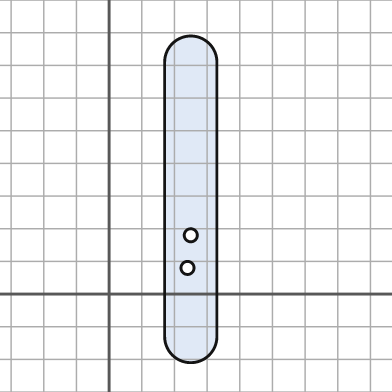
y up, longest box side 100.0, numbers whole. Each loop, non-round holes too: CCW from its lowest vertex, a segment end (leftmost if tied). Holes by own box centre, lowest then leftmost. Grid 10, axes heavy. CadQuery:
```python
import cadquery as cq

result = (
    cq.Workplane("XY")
    .moveTo(17.0, -13.0)
    .threePointArc((25.0, -21.0), (33.0, -13.0))
    .lineTo(33.0, 71.0)
    .threePointArc((25.0, 79.0), (17.0, 71.0))
    .close()
    .moveTo(24.0, 8.0)
    .circle(2.0)
    .moveTo(25.0, 18.0)
    .circle(2.0)
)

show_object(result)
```